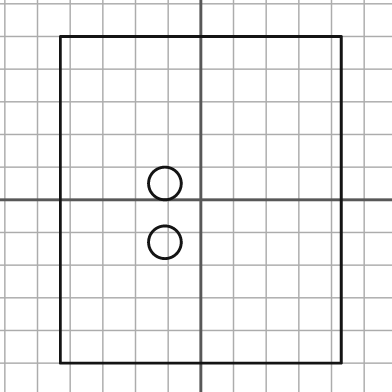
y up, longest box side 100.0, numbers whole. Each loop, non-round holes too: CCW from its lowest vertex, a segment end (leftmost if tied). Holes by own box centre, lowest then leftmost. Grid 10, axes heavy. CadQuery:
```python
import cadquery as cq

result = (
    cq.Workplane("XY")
    .moveTo(-43.0, -50.0)
    .lineTo(43.0, -50.0)
    .lineTo(43.0, 50.0)
    .lineTo(-43.0, 50.0)
    .close()
    .moveTo(-11.0, -13.0)
    .circle(5.0)
    .moveTo(-11.0, 5.0)
    .circle(5.0)
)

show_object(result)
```